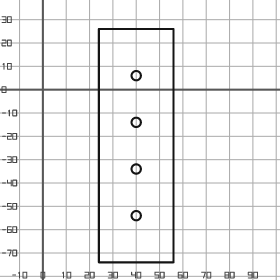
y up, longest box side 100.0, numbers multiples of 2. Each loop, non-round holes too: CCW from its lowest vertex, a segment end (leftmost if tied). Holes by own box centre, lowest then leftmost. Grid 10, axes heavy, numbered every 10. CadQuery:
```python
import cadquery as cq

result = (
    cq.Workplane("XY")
    .moveTo(24.0, -74.0)
    .lineTo(56.0, -74.0)
    .lineTo(56.0, 26.0)
    .lineTo(24.0, 26.0)
    .close()
    .moveTo(40.0, -54.0)
    .circle(2.0)
    .moveTo(40.0, -34.0)
    .circle(2.0)
    .moveTo(40.0, -14.0)
    .circle(2.0)
    .moveTo(40.0, 6.0)
    .circle(2.0)
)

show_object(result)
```